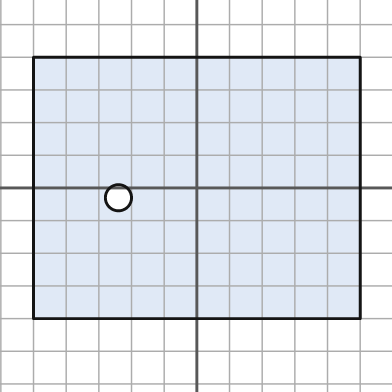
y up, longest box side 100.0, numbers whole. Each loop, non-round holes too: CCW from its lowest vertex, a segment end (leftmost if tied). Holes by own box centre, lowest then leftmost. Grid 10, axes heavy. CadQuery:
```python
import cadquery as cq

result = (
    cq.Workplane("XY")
    .moveTo(-50.0, -40.0)
    .lineTo(50.0, -40.0)
    .lineTo(50.0, 40.0)
    .lineTo(-50.0, 40.0)
    .close()
    .moveTo(-24.0, -3.0)
    .circle(4.0)
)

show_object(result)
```